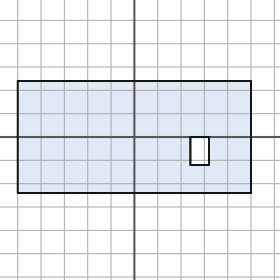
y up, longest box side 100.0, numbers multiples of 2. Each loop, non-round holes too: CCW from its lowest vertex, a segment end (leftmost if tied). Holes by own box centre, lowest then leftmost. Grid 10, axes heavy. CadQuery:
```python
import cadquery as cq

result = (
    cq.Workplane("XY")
    .moveTo(-50.0, -24.0)
    .lineTo(50.0, -24.0)
    .lineTo(50.0, 24.0)
    .lineTo(-50.0, 24.0)
    .close()
    .moveTo(24.0, -12.0)
    .lineTo(32.0, -12.0)
    .lineTo(32.0, 0.0)
    .lineTo(24.0, 0.0)
    .close()
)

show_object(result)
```